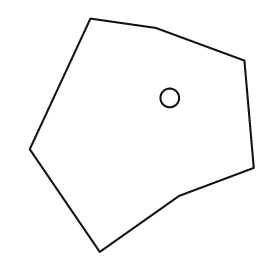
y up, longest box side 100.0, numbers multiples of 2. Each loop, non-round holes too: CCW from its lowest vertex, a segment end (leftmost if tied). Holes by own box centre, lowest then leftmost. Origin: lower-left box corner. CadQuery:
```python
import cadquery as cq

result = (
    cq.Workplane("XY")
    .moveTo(30.0, 0.0)
    .lineTo(64.0, 24.0)
    .lineTo(96.0, 36.0)
    .lineTo(92.0, 82.0)
    .lineTo(54.0, 96.0)
    .lineTo(26.0, 100.0)
    .lineTo(0.0, 44.0)
    .close()
    .moveTo(60.0, 66.0)
    .circle(4.0)
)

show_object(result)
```